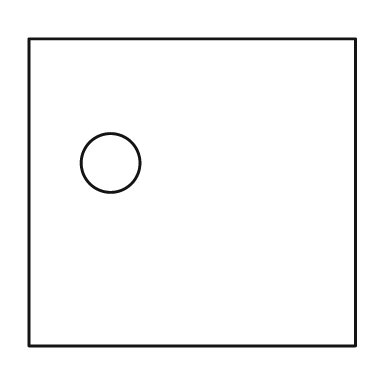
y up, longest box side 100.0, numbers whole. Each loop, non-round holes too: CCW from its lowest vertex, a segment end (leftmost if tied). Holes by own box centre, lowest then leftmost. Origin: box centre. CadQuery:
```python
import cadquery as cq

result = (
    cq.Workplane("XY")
    .moveTo(-50.0, -47.0)
    .lineTo(50.0, -47.0)
    .lineTo(50.0, 47.0)
    .lineTo(-50.0, 47.0)
    .close()
    .moveTo(-25.0, 9.0)
    .circle(9.0)
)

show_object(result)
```